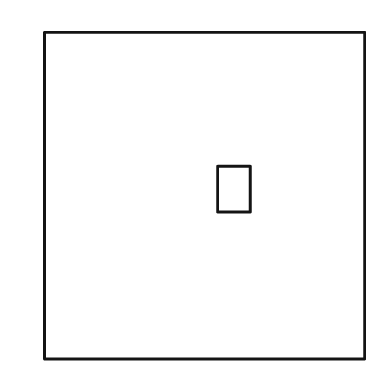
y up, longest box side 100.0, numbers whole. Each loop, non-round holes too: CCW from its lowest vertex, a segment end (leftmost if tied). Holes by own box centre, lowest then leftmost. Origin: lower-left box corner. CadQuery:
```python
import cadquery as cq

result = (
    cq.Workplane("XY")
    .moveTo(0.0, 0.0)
    .lineTo(98.0, 0.0)
    .lineTo(98.0, 100.0)
    .lineTo(0.0, 100.0)
    .close()
    .moveTo(53.0, 45.0)
    .lineTo(63.0, 45.0)
    .lineTo(63.0, 59.0)
    .lineTo(53.0, 59.0)
    .close()
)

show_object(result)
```